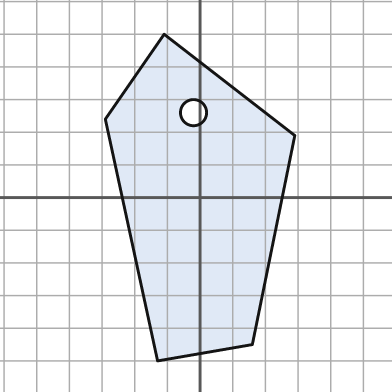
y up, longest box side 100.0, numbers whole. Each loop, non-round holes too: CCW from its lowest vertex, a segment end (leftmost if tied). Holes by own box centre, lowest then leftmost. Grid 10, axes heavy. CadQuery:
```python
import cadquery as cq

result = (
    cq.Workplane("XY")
    .moveTo(-13.0, -50.0)
    .lineTo(16.0, -45.0)
    .lineTo(29.0, 19.0)
    .lineTo(-11.0, 50.0)
    .lineTo(-29.0, 24.0)
    .close()
    .moveTo(-2.0, 26.0)
    .circle(4.0)
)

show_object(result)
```